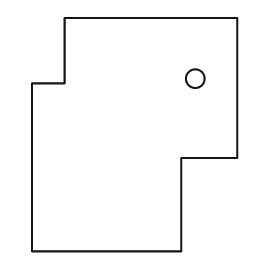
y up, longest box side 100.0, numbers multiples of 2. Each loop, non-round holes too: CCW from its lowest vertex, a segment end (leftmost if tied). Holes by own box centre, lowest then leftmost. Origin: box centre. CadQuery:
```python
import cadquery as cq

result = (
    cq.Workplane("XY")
    .moveTo(-44.0, -50.0)
    .lineTo(20.0, -50.0)
    .lineTo(20.0, -10.0)
    .lineTo(44.0, -10.0)
    .lineTo(44.0, 50.0)
    .lineTo(-30.0, 50.0)
    .lineTo(-30.0, 22.0)
    .lineTo(-44.0, 22.0)
    .close()
    .moveTo(26.0, 24.0)
    .circle(4.0)
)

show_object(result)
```